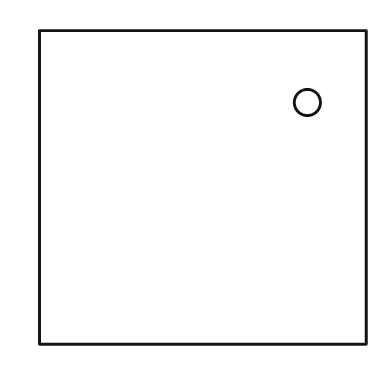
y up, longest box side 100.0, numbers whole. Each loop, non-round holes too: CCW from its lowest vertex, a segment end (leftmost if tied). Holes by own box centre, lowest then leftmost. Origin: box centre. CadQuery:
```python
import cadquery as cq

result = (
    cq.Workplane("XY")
    .moveTo(-50.0, -48.0)
    .lineTo(50.0, -48.0)
    .lineTo(50.0, 48.0)
    .lineTo(-50.0, 48.0)
    .close()
    .moveTo(32.0, 26.0)
    .circle(4.0)
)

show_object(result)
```